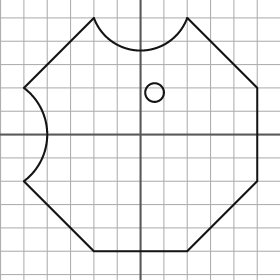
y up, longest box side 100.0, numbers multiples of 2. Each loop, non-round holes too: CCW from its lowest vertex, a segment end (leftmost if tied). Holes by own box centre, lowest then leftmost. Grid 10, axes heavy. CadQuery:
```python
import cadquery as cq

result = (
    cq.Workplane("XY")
    .moveTo(-20.0, -50.0)
    .lineTo(20.0, -50.0)
    .lineTo(50.0, -20.0)
    .lineTo(50.0, 20.0)
    .lineTo(20.0, 50.0)
    .threePointArc((0.0, 36.0), (-20.0, 50.0))
    .lineTo(-50.0, 20.0)
    .threePointArc((-40.0, 0.0), (-50.0, -20.0))
    .close()
    .moveTo(6.0, 18.0)
    .circle(4.0)
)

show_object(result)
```